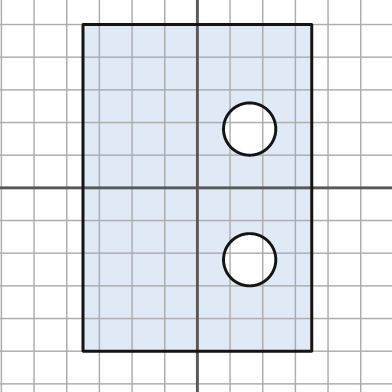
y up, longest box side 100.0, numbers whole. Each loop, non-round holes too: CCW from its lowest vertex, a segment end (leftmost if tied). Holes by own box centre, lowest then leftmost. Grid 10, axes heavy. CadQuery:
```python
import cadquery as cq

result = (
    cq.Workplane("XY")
    .moveTo(-35.0, -50.0)
    .lineTo(35.0, -50.0)
    .lineTo(35.0, 50.0)
    .lineTo(-35.0, 50.0)
    .close()
    .moveTo(16.0, -22.0)
    .circle(8.0)
    .moveTo(16.0, 18.0)
    .circle(8.0)
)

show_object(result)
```